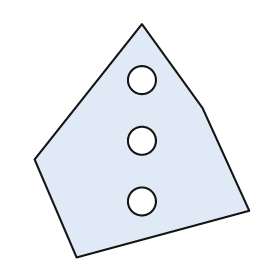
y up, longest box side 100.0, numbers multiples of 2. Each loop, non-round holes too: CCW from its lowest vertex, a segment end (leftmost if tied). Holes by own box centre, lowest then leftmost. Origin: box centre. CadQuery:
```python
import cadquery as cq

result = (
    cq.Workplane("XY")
    .moveTo(-28.0, -50.0)
    .lineTo(46.0, -30.0)
    .lineTo(26.0, 14.0)
    .lineTo(0.0, 50.0)
    .lineTo(-46.0, -8.0)
    .close()
    .moveTo(0.0, -26.0)
    .circle(6.0)
    .moveTo(0.0, 0.0)
    .circle(6.0)
    .moveTo(0.0, 26.0)
    .circle(6.0)
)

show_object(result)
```